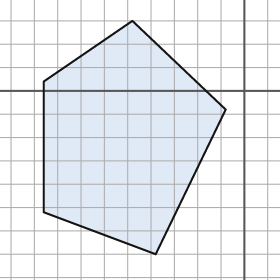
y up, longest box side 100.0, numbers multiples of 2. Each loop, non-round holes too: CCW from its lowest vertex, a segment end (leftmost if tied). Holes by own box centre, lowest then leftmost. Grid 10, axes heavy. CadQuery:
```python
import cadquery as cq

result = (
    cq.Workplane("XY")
    .moveTo(-38.0, -70.0)
    .lineTo(-8.0, -8.0)
    .lineTo(-48.0, 30.0)
    .lineTo(-86.0, 4.0)
    .lineTo(-86.0, -52.0)
    .close()
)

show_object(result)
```